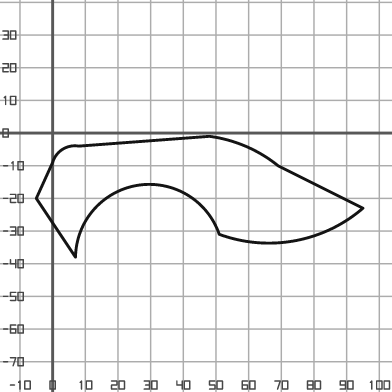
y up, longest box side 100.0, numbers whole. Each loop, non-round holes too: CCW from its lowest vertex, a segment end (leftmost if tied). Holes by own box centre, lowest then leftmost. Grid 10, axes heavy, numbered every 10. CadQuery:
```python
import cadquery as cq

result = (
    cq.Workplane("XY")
    .moveTo(7.0, -38.0)
    .threePointArc((26.0, -16.0), (51.0, -31.0))
    .threePointArc((74.0, -33.0), (95.0, -23.0))
    .lineTo(69.0, -10.0)
    .threePointArc((59.0, -4.0), (48.0, -1.0))
    .lineTo(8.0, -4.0)
    .threePointArc((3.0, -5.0), (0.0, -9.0))
    .lineTo(-5.0, -20.0)
    .close()
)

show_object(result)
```